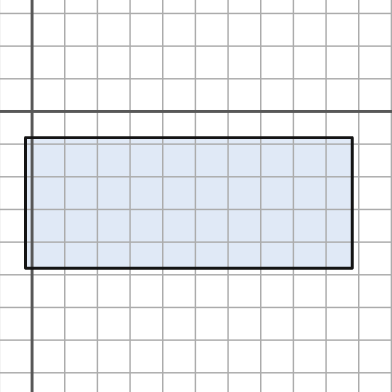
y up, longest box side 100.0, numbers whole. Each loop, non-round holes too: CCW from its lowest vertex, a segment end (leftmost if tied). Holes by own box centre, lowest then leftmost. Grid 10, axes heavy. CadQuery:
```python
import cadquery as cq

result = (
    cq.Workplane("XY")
    .moveTo(-2.0, -48.0)
    .lineTo(98.0, -48.0)
    .lineTo(98.0, -8.0)
    .lineTo(-2.0, -8.0)
    .close()
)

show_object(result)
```